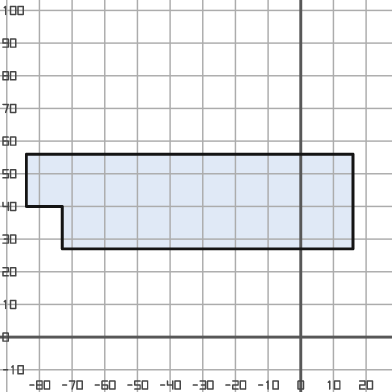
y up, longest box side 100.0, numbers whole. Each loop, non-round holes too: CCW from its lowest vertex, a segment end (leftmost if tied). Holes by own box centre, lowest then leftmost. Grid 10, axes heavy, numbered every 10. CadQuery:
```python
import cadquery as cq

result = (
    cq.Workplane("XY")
    .moveTo(-73.0, 27.0)
    .lineTo(16.0, 27.0)
    .lineTo(16.0, 56.0)
    .lineTo(-84.0, 56.0)
    .lineTo(-84.0, 40.0)
    .lineTo(-73.0, 40.0)
    .close()
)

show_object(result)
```